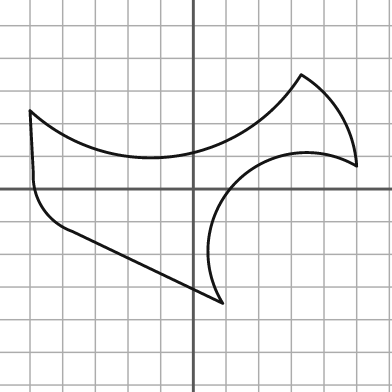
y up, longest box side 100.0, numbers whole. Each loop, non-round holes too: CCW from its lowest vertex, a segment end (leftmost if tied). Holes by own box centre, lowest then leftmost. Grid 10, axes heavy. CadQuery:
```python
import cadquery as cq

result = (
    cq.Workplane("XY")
    .moveTo(9.0, -35.0)
    .threePointArc((13.0, 2.0), (50.0, 7.0))
    .threePointArc((45.0, 23.0), (33.0, 35.0))
    .threePointArc((-6.0, 10.0), (-50.0, 24.0))
    .lineTo(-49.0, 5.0)
    .threePointArc((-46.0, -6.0), (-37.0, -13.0))
    .close()
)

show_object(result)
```